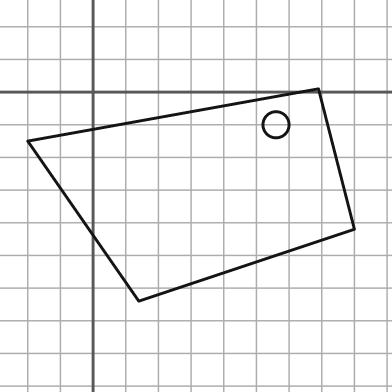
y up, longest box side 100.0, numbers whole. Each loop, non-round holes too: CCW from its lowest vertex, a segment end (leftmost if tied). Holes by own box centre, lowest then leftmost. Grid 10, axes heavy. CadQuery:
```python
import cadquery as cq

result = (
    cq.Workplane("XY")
    .moveTo(14.0, -64.0)
    .lineTo(80.0, -42.0)
    .lineTo(69.0, 1.0)
    .lineTo(-20.0, -15.0)
    .close()
    .moveTo(56.0, -10.0)
    .circle(4.0)
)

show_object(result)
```